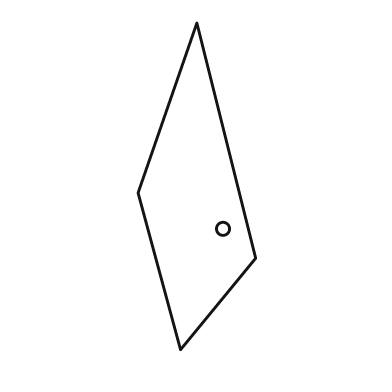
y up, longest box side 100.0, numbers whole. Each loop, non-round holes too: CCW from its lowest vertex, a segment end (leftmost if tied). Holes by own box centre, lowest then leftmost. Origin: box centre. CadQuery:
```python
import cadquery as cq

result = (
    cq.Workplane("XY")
    .moveTo(-5.0, -50.0)
    .lineTo(18.0, -22.0)
    .lineTo(0.0, 50.0)
    .lineTo(-18.0, -2.0)
    .close()
    .moveTo(8.0, -13.0)
    .circle(2.0)
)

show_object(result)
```